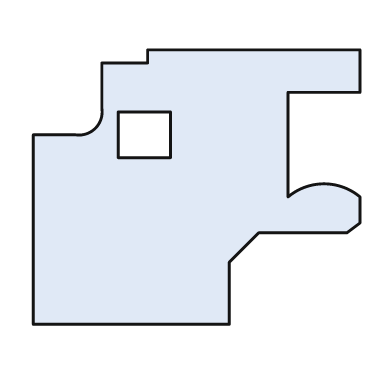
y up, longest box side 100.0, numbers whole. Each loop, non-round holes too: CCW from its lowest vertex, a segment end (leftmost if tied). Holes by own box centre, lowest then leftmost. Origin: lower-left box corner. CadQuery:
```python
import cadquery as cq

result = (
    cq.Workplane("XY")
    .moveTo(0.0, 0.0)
    .lineTo(60.0, 0.0)
    .lineTo(60.0, 19.0)
    .lineTo(69.0, 28.0)
    .lineTo(96.0, 28.0)
    .lineTo(100.0, 31.0)
    .lineTo(100.0, 39.0)
    .threePointArc((89.0, 43.0), (78.0, 39.0))
    .lineTo(78.0, 71.0)
    .lineTo(100.0, 71.0)
    .lineTo(100.0, 84.0)
    .lineTo(35.0, 84.0)
    .lineTo(35.0, 80.0)
    .lineTo(21.0, 80.0)
    .lineTo(21.0, 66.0)
    .threePointArc((19.0, 60.0), (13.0, 58.0))
    .lineTo(0.0, 58.0)
    .close()
    .moveTo(26.0, 51.0)
    .lineTo(42.0, 51.0)
    .lineTo(42.0, 65.0)
    .lineTo(26.0, 65.0)
    .close()
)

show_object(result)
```